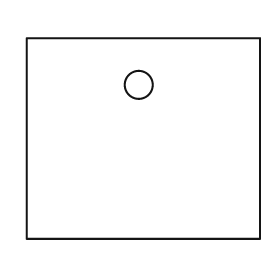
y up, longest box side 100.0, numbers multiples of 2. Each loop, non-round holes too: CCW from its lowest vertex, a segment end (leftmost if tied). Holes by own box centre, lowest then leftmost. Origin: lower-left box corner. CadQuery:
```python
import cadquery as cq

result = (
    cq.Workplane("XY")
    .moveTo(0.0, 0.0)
    .lineTo(100.0, 0.0)
    .lineTo(100.0, 86.0)
    .lineTo(0.0, 86.0)
    .close()
    .moveTo(48.0, 66.0)
    .circle(6.0)
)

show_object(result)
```